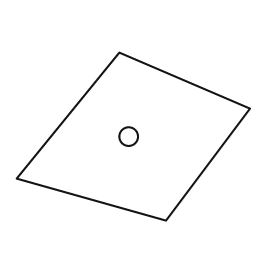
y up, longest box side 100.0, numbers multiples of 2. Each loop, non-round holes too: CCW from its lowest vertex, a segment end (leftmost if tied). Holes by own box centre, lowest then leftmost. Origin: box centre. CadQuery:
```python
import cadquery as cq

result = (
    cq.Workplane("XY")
    .moveTo(14.0, -36.0)
    .lineTo(50.0, 12.0)
    .lineTo(-6.0, 36.0)
    .lineTo(-50.0, -18.0)
    .close()
    .moveTo(-2.0, 0.0)
    .circle(4.0)
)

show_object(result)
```